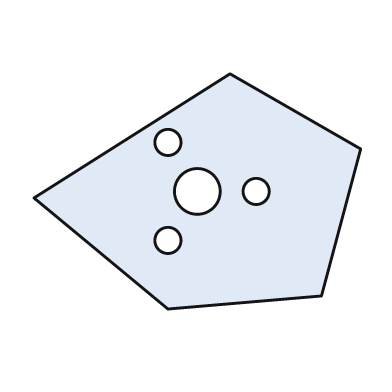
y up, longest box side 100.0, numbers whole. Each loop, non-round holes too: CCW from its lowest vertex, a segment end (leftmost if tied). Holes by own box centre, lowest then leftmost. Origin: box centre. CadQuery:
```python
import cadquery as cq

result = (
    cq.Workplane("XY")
    .moveTo(-9.0, -36.0)
    .lineTo(38.0, -32.0)
    .lineTo(50.0, 13.0)
    .lineTo(10.0, 36.0)
    .lineTo(-50.0, -2.0)
    .close()
    .moveTo(-9.0, -15.0)
    .circle(4.0)
    .moveTo(0.0, 0.0)
    .circle(7.0)
    .moveTo(18.0, 0.0)
    .circle(4.0)
    .moveTo(-9.0, 15.0)
    .circle(4.0)
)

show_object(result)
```